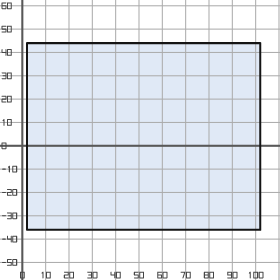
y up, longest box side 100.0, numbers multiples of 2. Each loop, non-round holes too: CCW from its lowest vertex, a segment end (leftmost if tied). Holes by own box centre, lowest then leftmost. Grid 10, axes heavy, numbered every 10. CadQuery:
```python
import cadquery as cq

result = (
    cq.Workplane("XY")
    .moveTo(2.0, -36.0)
    .lineTo(102.0, -36.0)
    .lineTo(102.0, 44.0)
    .lineTo(2.0, 44.0)
    .close()
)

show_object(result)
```